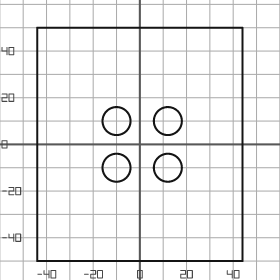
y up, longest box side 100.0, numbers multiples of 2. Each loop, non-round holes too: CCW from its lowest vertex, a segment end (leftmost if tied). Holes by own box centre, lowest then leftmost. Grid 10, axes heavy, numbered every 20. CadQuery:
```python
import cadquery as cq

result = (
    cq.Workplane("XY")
    .moveTo(-44.0, -50.0)
    .lineTo(44.0, -50.0)
    .lineTo(44.0, 50.0)
    .lineTo(-44.0, 50.0)
    .close()
    .moveTo(-10.0, -10.0)
    .circle(6.0)
    .moveTo(12.0, -10.0)
    .circle(6.0)
    .moveTo(-10.0, 10.0)
    .circle(6.0)
    .moveTo(12.0, 10.0)
    .circle(6.0)
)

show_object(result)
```